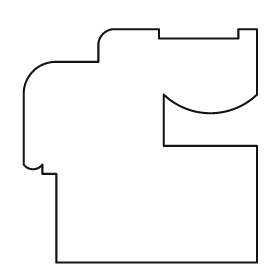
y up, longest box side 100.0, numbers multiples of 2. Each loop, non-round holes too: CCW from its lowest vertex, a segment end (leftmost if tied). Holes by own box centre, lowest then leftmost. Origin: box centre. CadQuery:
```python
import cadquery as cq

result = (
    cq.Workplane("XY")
    .moveTo(-36.0, -50.0)
    .lineTo(50.0, -50.0)
    .lineTo(50.0, 0.0)
    .lineTo(10.0, 0.0)
    .lineTo(10.0, 22.0)
    .threePointArc((30.0, 14.0), (50.0, 22.0))
    .lineTo(50.0, 50.0)
    .lineTo(42.0, 50.0)
    .lineTo(42.0, 46.0)
    .lineTo(8.0, 46.0)
    .lineTo(8.0, 50.0)
    .lineTo(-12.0, 50.0)
    .threePointArc((-16.0, 48.0), (-18.0, 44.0))
    .lineTo(-18.0, 36.0)
    .lineTo(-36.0, 36.0)
    .threePointArc((-46.0, 32.0), (-50.0, 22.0))
    .lineTo(-50.0, -8.0)
    .threePointArc((-46.0, -10.0), (-42.0, -8.0))
    .lineTo(-42.0, -12.0)
    .lineTo(-36.0, -12.0)
    .close()
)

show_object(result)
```